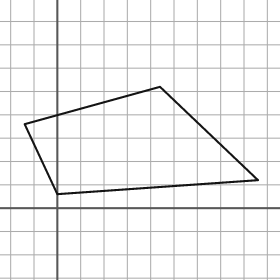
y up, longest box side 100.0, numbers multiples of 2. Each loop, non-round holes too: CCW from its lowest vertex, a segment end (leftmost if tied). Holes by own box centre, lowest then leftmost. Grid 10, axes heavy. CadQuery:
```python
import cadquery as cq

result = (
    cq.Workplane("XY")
    .moveTo(0.0, 6.0)
    .lineTo(86.0, 12.0)
    .lineTo(44.0, 52.0)
    .lineTo(-14.0, 36.0)
    .close()
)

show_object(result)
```